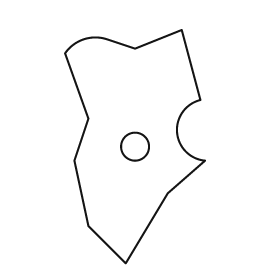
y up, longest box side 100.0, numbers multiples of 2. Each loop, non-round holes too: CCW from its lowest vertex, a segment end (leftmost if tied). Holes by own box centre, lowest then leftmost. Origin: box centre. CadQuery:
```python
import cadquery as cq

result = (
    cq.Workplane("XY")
    .moveTo(-4.0, -50.0)
    .lineTo(14.0, -20.0)
    .lineTo(30.0, -6.0)
    .threePointArc((18.0, 6.0), (28.0, 20.0))
    .lineTo(20.0, 50.0)
    .lineTo(0.0, 42.0)
    .lineTo(-12.0, 46.0)
    .threePointArc((-22.0, 46.0), (-30.0, 40.0))
    .lineTo(-20.0, 12.0)
    .lineTo(-26.0, -6.0)
    .lineTo(-20.0, -34.0)
    .close()
    .moveTo(0.0, 0.0)
    .circle(6.0)
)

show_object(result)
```